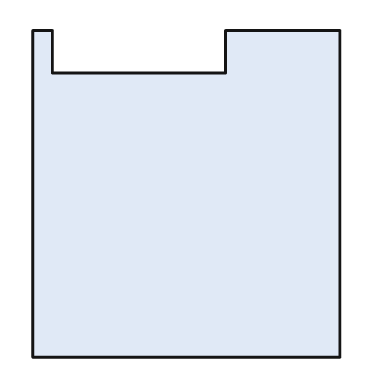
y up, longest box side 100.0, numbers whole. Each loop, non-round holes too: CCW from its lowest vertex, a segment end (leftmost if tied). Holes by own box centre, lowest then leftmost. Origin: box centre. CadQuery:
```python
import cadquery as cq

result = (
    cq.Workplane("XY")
    .moveTo(-47.0, -50.0)
    .lineTo(47.0, -50.0)
    .lineTo(47.0, 50.0)
    .lineTo(12.0, 50.0)
    .lineTo(12.0, 37.0)
    .lineTo(-41.0, 37.0)
    .lineTo(-41.0, 50.0)
    .lineTo(-47.0, 50.0)
    .close()
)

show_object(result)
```